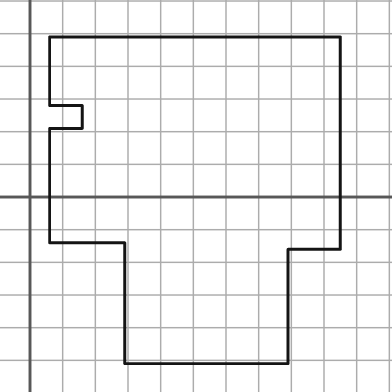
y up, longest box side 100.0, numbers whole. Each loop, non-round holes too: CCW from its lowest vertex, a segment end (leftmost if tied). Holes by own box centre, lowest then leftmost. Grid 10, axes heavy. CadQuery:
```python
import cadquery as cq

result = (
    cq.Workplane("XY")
    .moveTo(29.0, -51.0)
    .lineTo(79.0, -51.0)
    .lineTo(79.0, -16.0)
    .lineTo(95.0, -16.0)
    .lineTo(95.0, 49.0)
    .lineTo(6.0, 49.0)
    .lineTo(6.0, 28.0)
    .lineTo(16.0, 28.0)
    .lineTo(16.0, 21.0)
    .lineTo(6.0, 21.0)
    .lineTo(6.0, -14.0)
    .lineTo(29.0, -14.0)
    .close()
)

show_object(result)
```